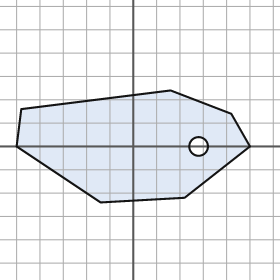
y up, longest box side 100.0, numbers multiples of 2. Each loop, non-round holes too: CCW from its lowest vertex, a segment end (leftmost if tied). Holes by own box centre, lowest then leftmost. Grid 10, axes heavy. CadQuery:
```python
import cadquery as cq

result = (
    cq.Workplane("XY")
    .moveTo(-14.0, -24.0)
    .lineTo(22.0, -22.0)
    .lineTo(50.0, 0.0)
    .lineTo(42.0, 14.0)
    .lineTo(16.0, 24.0)
    .lineTo(-48.0, 16.0)
    .lineTo(-50.0, 0.0)
    .close()
    .moveTo(28.0, 0.0)
    .circle(4.0)
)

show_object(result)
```